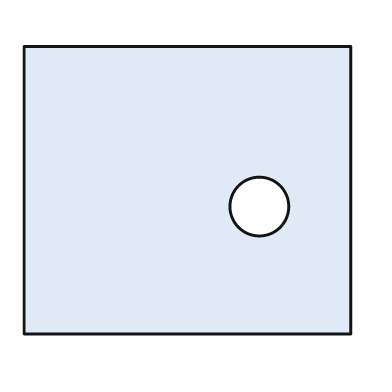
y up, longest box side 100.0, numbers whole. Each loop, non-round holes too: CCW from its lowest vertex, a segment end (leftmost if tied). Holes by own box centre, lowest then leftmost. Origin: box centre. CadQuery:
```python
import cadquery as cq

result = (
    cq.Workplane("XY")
    .moveTo(-50.0, -44.0)
    .lineTo(50.0, -44.0)
    .lineTo(50.0, 44.0)
    .lineTo(-50.0, 44.0)
    .close()
    .moveTo(22.0, -5.0)
    .circle(9.0)
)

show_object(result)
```